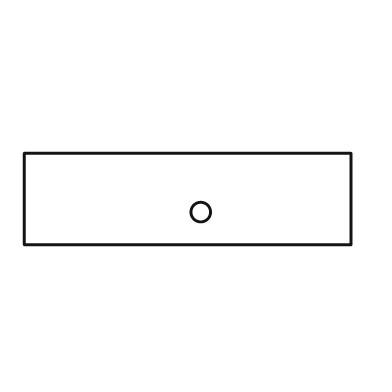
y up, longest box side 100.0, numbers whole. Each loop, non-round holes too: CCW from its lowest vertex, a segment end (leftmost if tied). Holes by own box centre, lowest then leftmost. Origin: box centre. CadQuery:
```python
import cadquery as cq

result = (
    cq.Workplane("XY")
    .moveTo(-50.0, -14.0)
    .lineTo(50.0, -14.0)
    .lineTo(50.0, 14.0)
    .lineTo(-50.0, 14.0)
    .close()
    .moveTo(4.0, -4.0)
    .circle(3.0)
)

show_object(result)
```